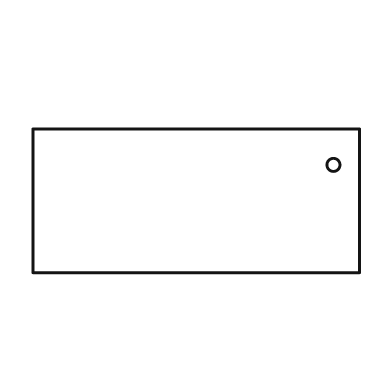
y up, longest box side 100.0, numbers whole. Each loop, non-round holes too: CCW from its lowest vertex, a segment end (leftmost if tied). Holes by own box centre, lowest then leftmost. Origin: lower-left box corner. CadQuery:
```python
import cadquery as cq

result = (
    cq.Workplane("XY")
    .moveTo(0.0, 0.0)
    .lineTo(100.0, 0.0)
    .lineTo(100.0, 44.0)
    .lineTo(0.0, 44.0)
    .close()
    .moveTo(92.0, 33.0)
    .circle(2.0)
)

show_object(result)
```